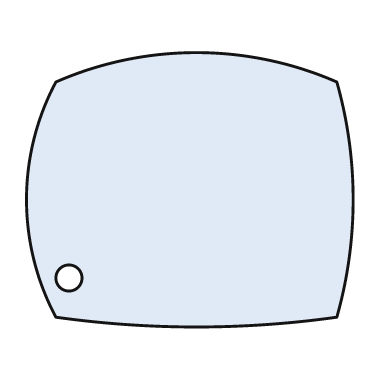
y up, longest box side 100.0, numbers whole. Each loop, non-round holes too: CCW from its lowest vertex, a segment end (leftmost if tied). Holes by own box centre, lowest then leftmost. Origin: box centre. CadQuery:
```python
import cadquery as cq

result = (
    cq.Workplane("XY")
    .moveTo(-41.0, -39.0)
    .threePointArc((2.0, -42.0), (45.0, -39.0))
    .threePointArc((50.0, -3.0), (45.0, 33.0))
    .threePointArc((2.0, 42.0), (-41.0, 33.0))
    .threePointArc((-50.0, -3.0), (-41.0, -39.0))
    .close()
    .moveTo(-37.0, -27.0)
    .circle(4.0)
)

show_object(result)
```